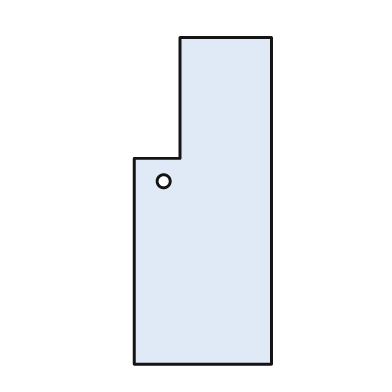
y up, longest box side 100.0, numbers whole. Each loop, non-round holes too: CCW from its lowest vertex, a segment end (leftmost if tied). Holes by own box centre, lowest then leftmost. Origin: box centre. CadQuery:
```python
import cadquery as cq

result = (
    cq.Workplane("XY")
    .moveTo(-21.0, -50.0)
    .lineTo(21.0, -50.0)
    .lineTo(21.0, 50.0)
    .lineTo(-7.0, 50.0)
    .lineTo(-7.0, 13.0)
    .lineTo(-21.0, 13.0)
    .close()
    .moveTo(-12.0, 6.0)
    .circle(2.0)
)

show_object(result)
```